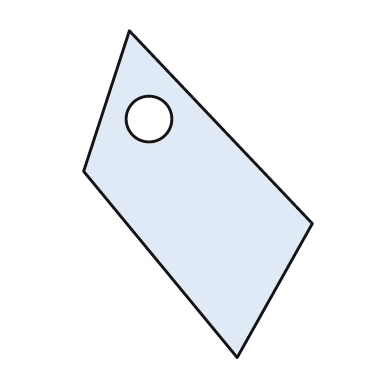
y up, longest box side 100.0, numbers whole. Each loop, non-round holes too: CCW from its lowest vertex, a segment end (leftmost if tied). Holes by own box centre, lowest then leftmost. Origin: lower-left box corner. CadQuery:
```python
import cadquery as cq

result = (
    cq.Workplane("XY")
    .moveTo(47.0, 0.0)
    .lineTo(70.0, 41.0)
    .lineTo(14.0, 100.0)
    .lineTo(0.0, 57.0)
    .close()
    .moveTo(20.0, 73.0)
    .circle(7.0)
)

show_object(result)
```